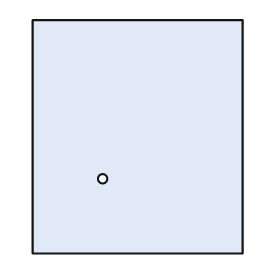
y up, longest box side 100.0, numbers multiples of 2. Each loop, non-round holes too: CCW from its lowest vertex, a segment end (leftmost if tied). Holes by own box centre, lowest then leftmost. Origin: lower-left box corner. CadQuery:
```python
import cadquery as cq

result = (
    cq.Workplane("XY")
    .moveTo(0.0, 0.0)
    .lineTo(90.0, 0.0)
    .lineTo(90.0, 100.0)
    .lineTo(0.0, 100.0)
    .close()
    .moveTo(30.0, 32.0)
    .circle(2.0)
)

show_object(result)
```